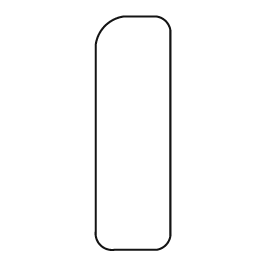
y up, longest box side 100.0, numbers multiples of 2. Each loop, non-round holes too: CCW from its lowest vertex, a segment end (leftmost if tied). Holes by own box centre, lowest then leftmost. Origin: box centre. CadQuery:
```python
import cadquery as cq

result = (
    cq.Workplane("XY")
    .moveTo(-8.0, -50.0)
    .lineTo(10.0, -50.0)
    .threePointArc((14.0, -48.0), (16.0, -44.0))
    .lineTo(16.0, 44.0)
    .threePointArc((14.0, 48.0), (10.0, 50.0))
    .lineTo(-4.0, 50.0)
    .threePointArc((-12.0, 46.0), (-16.0, 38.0))
    .lineTo(-16.0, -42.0)
    .threePointArc((-14.0, -48.0), (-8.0, -50.0))
    .close()
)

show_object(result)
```